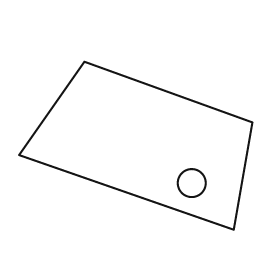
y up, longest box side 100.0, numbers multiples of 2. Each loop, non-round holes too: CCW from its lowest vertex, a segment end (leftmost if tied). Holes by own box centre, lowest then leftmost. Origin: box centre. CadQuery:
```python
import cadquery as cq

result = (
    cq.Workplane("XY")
    .moveTo(42.0, -36.0)
    .lineTo(50.0, 10.0)
    .lineTo(-22.0, 36.0)
    .lineTo(-50.0, -4.0)
    .close()
    .moveTo(24.0, -16.0)
    .circle(6.0)
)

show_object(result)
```